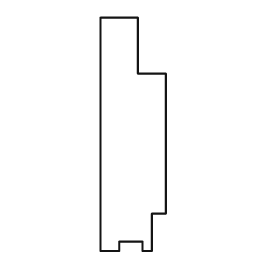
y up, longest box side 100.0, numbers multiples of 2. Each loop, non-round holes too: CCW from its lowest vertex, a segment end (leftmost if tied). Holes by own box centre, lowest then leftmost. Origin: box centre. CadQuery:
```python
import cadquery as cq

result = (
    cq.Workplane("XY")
    .moveTo(-14.0, -50.0)
    .lineTo(-6.0, -50.0)
    .lineTo(-6.0, -46.0)
    .lineTo(4.0, -46.0)
    .lineTo(4.0, -50.0)
    .lineTo(8.0, -50.0)
    .lineTo(8.0, -34.0)
    .lineTo(14.0, -34.0)
    .lineTo(14.0, 26.0)
    .lineTo(2.0, 26.0)
    .lineTo(2.0, 50.0)
    .lineTo(-14.0, 50.0)
    .close()
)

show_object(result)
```